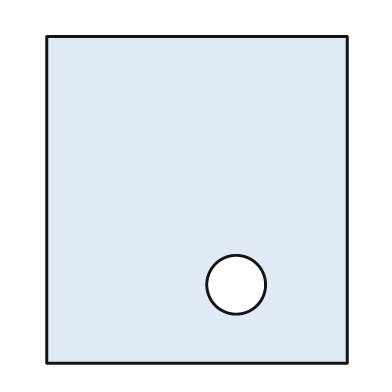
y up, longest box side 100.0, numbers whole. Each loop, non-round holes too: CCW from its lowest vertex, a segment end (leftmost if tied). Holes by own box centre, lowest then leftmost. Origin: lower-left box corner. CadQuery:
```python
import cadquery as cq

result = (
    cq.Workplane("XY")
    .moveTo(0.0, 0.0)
    .lineTo(92.0, 0.0)
    .lineTo(92.0, 100.0)
    .lineTo(0.0, 100.0)
    .close()
    .moveTo(58.0, 24.0)
    .circle(9.0)
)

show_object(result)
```